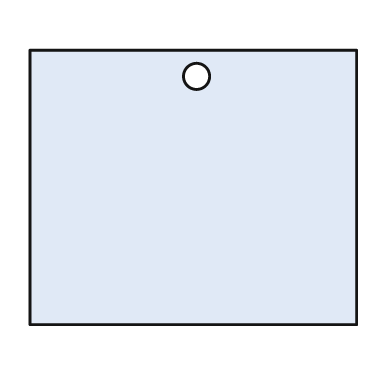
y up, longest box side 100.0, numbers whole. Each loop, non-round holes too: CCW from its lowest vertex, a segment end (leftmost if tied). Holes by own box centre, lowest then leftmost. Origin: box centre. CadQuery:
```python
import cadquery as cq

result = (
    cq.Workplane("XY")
    .moveTo(-50.0, -42.0)
    .lineTo(50.0, -42.0)
    .lineTo(50.0, 42.0)
    .lineTo(-50.0, 42.0)
    .close()
    .moveTo(1.0, 34.0)
    .circle(4.0)
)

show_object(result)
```